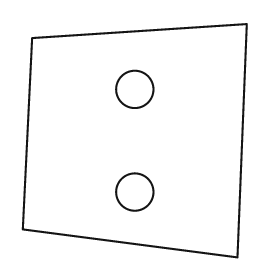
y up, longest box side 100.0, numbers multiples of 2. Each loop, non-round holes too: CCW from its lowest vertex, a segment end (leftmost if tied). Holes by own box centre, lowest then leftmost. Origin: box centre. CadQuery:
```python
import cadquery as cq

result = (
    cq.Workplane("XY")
    .moveTo(44.0, -50.0)
    .lineTo(48.0, 50.0)
    .lineTo(-44.0, 44.0)
    .lineTo(-48.0, -38.0)
    .close()
    .moveTo(0.0, -22.0)
    .circle(8.0)
    .moveTo(0.0, 22.0)
    .circle(8.0)
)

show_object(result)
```